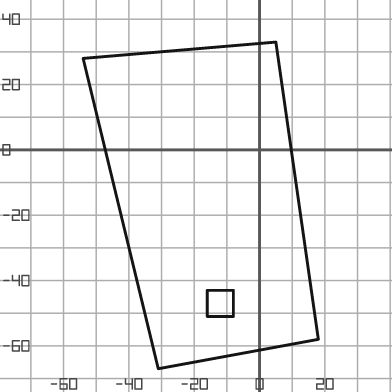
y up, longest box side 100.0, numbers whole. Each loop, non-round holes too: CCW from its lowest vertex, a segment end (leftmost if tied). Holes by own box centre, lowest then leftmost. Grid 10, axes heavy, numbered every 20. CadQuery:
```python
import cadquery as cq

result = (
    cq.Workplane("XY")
    .moveTo(-31.0, -67.0)
    .lineTo(18.0, -58.0)
    .lineTo(5.0, 33.0)
    .lineTo(-54.0, 28.0)
    .close()
    .moveTo(-16.0, -51.0)
    .lineTo(-8.0, -51.0)
    .lineTo(-8.0, -43.0)
    .lineTo(-16.0, -43.0)
    .close()
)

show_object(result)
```